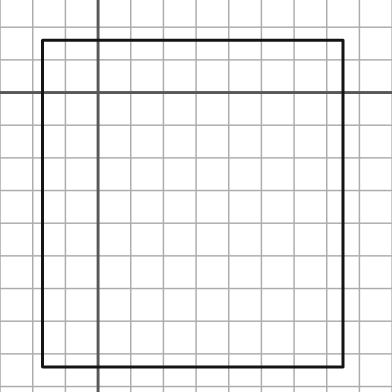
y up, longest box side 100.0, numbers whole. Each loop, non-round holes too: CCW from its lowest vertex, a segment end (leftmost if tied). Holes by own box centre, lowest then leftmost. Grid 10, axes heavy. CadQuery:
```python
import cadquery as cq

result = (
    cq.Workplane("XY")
    .moveTo(-17.0, -84.0)
    .lineTo(75.0, -84.0)
    .lineTo(75.0, 16.0)
    .lineTo(-17.0, 16.0)
    .close()
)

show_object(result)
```